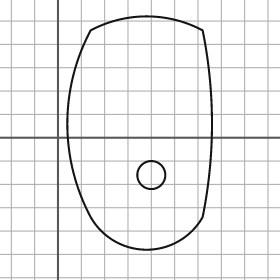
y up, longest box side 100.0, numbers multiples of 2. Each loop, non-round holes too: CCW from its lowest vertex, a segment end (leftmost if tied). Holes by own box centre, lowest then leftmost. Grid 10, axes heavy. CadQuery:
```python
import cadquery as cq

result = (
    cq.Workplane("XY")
    .moveTo(14.0, -34.0)
    .threePointArc((38.0, -48.0), (62.0, -34.0))
    .threePointArc((66.0, 6.0), (62.0, 46.0))
    .threePointArc((38.0, 52.0), (14.0, 46.0))
    .threePointArc((4.0, 6.0), (14.0, -34.0))
    .close()
    .moveTo(40.0, -16.0)
    .circle(6.0)
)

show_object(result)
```